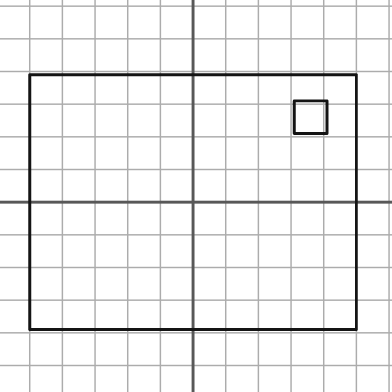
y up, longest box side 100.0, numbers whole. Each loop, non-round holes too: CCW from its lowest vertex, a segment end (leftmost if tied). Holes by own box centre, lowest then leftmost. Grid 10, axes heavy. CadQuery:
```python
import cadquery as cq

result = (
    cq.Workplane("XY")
    .moveTo(-50.0, -39.0)
    .lineTo(50.0, -39.0)
    .lineTo(50.0, 39.0)
    .lineTo(-50.0, 39.0)
    .close()
    .moveTo(31.0, 21.0)
    .lineTo(41.0, 21.0)
    .lineTo(41.0, 31.0)
    .lineTo(31.0, 31.0)
    .close()
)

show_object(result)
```